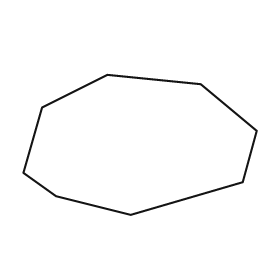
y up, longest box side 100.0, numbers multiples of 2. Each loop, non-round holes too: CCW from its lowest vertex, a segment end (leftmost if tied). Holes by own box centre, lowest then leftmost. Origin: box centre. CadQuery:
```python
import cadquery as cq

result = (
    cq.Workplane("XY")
    .moveTo(-4.0, -30.0)
    .lineTo(44.0, -16.0)
    .lineTo(50.0, 6.0)
    .lineTo(26.0, 26.0)
    .lineTo(-14.0, 30.0)
    .lineTo(-42.0, 16.0)
    .lineTo(-50.0, -12.0)
    .lineTo(-36.0, -22.0)
    .close()
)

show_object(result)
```